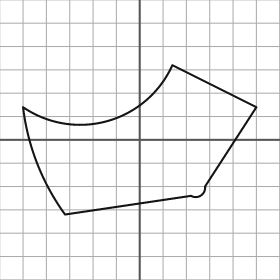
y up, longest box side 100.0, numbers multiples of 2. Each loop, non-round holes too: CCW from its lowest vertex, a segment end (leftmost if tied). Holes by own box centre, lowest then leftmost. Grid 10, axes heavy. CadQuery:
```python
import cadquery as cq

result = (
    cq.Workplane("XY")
    .moveTo(-32.0, -32.0)
    .lineTo(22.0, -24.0)
    .threePointArc((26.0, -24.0), (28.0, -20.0))
    .lineTo(50.0, 14.0)
    .lineTo(14.0, 32.0)
    .threePointArc((-14.0, 8.0), (-50.0, 14.0))
    .threePointArc((-44.0, -10.0), (-32.0, -32.0))
    .close()
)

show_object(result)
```